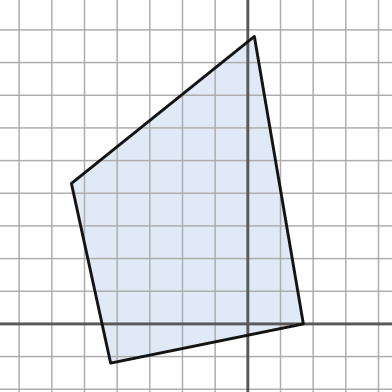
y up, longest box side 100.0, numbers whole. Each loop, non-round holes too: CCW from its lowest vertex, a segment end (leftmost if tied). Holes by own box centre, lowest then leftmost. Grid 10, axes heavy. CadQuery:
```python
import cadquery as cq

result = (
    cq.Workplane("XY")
    .moveTo(-42.0, -12.0)
    .lineTo(17.0, 0.0)
    .lineTo(2.0, 88.0)
    .lineTo(-54.0, 43.0)
    .close()
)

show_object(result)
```